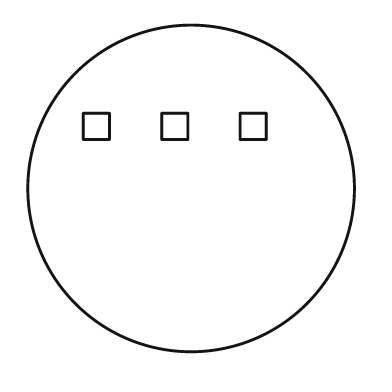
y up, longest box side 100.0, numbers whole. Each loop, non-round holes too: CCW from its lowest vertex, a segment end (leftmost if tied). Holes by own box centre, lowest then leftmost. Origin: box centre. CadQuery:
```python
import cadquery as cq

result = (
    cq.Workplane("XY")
    .moveTo(0.0, 0.0)
    .circle(50.0)
    .moveTo(-33.0, 15.0)
    .lineTo(-25.0, 15.0)
    .lineTo(-25.0, 23.0)
    .lineTo(-33.0, 23.0)
    .close()
    .moveTo(-9.0, 15.0)
    .lineTo(-1.0, 15.0)
    .lineTo(-1.0, 23.0)
    .lineTo(-9.0, 23.0)
    .close()
    .moveTo(15.0, 15.0)
    .lineTo(23.0, 15.0)
    .lineTo(23.0, 23.0)
    .lineTo(15.0, 23.0)
    .close()
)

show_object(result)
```